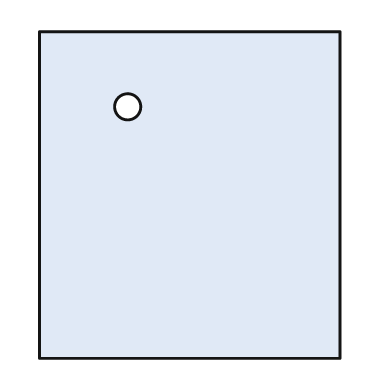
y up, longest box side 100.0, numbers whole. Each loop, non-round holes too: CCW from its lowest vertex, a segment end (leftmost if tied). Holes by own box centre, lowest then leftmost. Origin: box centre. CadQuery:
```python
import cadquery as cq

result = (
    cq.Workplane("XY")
    .moveTo(-46.0, -50.0)
    .lineTo(46.0, -50.0)
    .lineTo(46.0, 50.0)
    .lineTo(-46.0, 50.0)
    .close()
    .moveTo(-19.0, 27.0)
    .circle(4.0)
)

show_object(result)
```